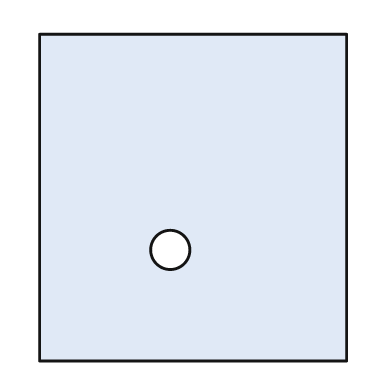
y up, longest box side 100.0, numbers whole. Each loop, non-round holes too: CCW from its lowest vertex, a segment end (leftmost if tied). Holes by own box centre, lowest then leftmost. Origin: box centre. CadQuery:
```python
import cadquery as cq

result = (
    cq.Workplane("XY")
    .moveTo(-47.0, -50.0)
    .lineTo(47.0, -50.0)
    .lineTo(47.0, 50.0)
    .lineTo(-47.0, 50.0)
    .close()
    .moveTo(-7.0, -16.0)
    .circle(6.0)
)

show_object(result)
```